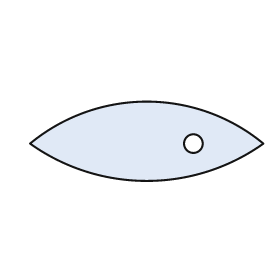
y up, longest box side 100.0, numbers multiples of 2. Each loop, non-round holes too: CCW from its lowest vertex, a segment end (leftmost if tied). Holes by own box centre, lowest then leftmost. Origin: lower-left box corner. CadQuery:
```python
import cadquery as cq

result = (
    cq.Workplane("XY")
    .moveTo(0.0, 16.0)
    .threePointArc((50.0, 0.0), (100.0, 16.0))
    .threePointArc((50.0, 34.0), (0.0, 16.0))
    .close()
    .moveTo(70.0, 16.0)
    .circle(4.0)
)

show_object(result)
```